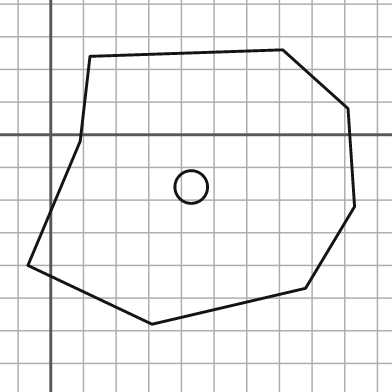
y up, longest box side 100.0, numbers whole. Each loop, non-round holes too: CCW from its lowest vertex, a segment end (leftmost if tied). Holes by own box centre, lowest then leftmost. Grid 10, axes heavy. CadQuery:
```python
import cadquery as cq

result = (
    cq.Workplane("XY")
    .moveTo(31.0, -58.0)
    .lineTo(78.0, -47.0)
    .lineTo(93.0, -22.0)
    .lineTo(91.0, 8.0)
    .lineTo(71.0, 26.0)
    .lineTo(12.0, 24.0)
    .lineTo(9.0, -2.0)
    .lineTo(-7.0, -40.0)
    .close()
    .moveTo(43.0, -16.0)
    .circle(5.0)
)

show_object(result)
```